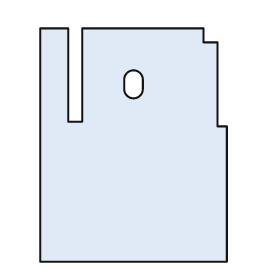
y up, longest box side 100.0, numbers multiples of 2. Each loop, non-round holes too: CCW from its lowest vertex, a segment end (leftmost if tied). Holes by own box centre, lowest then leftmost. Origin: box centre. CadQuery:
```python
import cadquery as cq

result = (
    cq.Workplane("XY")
    .moveTo(-40.0, -50.0)
    .lineTo(40.0, -50.0)
    .lineTo(40.0, 8.0)
    .lineTo(36.0, 8.0)
    .lineTo(36.0, 44.0)
    .lineTo(30.0, 44.0)
    .lineTo(30.0, 50.0)
    .lineTo(-22.0, 50.0)
    .lineTo(-22.0, 10.0)
    .lineTo(-28.0, 10.0)
    .lineTo(-28.0, 50.0)
    .lineTo(-40.0, 50.0)
    .close()
    .moveTo(-4.0, 24.0)
    .threePointArc((0.0, 20.0), (4.0, 24.0))
    .lineTo(4.0, 28.0)
    .threePointArc((0.0, 32.0), (-4.0, 28.0))
    .close()
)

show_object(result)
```